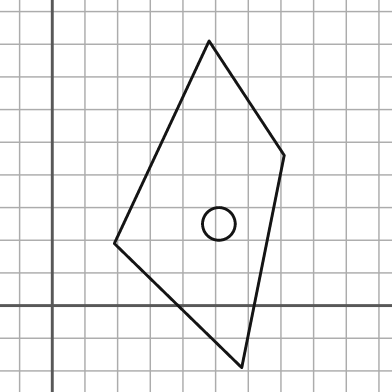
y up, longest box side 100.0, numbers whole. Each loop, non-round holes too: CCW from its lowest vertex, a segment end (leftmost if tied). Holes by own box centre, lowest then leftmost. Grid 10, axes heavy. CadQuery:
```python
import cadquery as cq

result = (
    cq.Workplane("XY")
    .moveTo(58.0, -19.0)
    .lineTo(71.0, 46.0)
    .lineTo(48.0, 81.0)
    .lineTo(19.0, 19.0)
    .close()
    .moveTo(51.0, 25.0)
    .circle(5.0)
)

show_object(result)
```